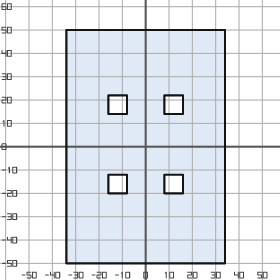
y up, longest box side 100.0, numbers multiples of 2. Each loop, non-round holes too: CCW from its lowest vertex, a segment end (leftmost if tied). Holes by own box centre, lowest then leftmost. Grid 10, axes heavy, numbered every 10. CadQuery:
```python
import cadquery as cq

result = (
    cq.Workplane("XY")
    .moveTo(-34.0, -50.0)
    .lineTo(34.0, -50.0)
    .lineTo(34.0, 50.0)
    .lineTo(-34.0, 50.0)
    .close()
    .moveTo(-16.0, -20.0)
    .lineTo(-8.0, -20.0)
    .lineTo(-8.0, -12.0)
    .lineTo(-16.0, -12.0)
    .close()
    .moveTo(8.0, -20.0)
    .lineTo(16.0, -20.0)
    .lineTo(16.0, -12.0)
    .lineTo(8.0, -12.0)
    .close()
    .moveTo(-16.0, 14.0)
    .lineTo(-8.0, 14.0)
    .lineTo(-8.0, 22.0)
    .lineTo(-16.0, 22.0)
    .close()
    .moveTo(8.0, 14.0)
    .lineTo(16.0, 14.0)
    .lineTo(16.0, 22.0)
    .lineTo(8.0, 22.0)
    .close()
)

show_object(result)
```